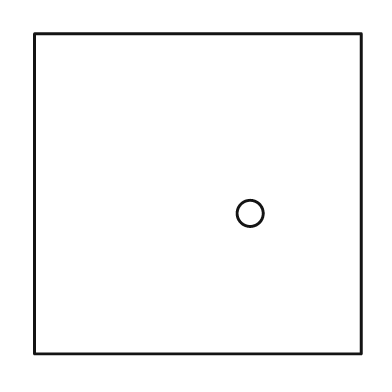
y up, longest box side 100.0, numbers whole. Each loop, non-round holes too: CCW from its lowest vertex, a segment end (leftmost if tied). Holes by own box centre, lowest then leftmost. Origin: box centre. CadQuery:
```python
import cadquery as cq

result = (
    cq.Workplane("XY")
    .moveTo(-50.0, -49.0)
    .lineTo(50.0, -49.0)
    .lineTo(50.0, 49.0)
    .lineTo(-50.0, 49.0)
    .close()
    .moveTo(16.0, -6.0)
    .circle(4.0)
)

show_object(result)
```